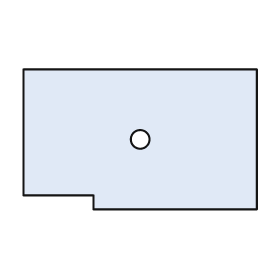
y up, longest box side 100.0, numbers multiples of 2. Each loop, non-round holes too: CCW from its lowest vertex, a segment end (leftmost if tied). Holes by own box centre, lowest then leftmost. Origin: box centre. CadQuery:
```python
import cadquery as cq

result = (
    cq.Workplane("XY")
    .moveTo(-20.0, -30.0)
    .lineTo(50.0, -30.0)
    .lineTo(50.0, 30.0)
    .lineTo(-50.0, 30.0)
    .lineTo(-50.0, -24.0)
    .lineTo(-20.0, -24.0)
    .close()
    .moveTo(0.0, 0.0)
    .circle(4.0)
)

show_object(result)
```